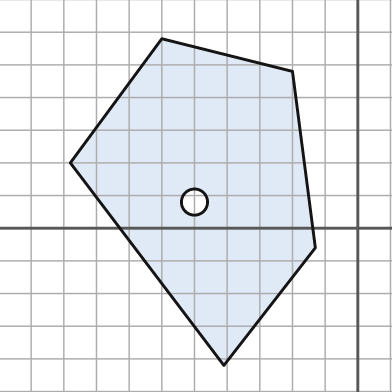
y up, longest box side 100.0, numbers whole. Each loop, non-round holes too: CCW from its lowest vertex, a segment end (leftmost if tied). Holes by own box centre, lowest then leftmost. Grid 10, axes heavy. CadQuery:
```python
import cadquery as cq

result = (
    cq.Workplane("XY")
    .moveTo(-41.0, -42.0)
    .lineTo(-13.0, -6.0)
    .lineTo(-20.0, 48.0)
    .lineTo(-60.0, 58.0)
    .lineTo(-88.0, 20.0)
    .close()
    .moveTo(-50.0, 8.0)
    .circle(4.0)
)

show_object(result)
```